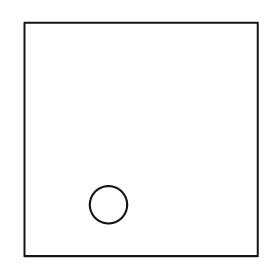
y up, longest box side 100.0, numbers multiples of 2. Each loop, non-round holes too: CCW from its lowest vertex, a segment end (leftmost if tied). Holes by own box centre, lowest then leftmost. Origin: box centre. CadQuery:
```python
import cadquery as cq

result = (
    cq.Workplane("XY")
    .moveTo(-50.0, -50.0)
    .lineTo(50.0, -50.0)
    .lineTo(50.0, 50.0)
    .lineTo(-50.0, 50.0)
    .close()
    .moveTo(-14.0, -28.0)
    .circle(8.0)
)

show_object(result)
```